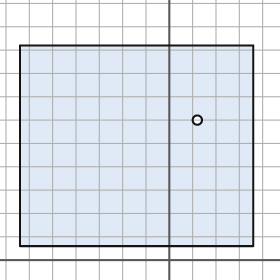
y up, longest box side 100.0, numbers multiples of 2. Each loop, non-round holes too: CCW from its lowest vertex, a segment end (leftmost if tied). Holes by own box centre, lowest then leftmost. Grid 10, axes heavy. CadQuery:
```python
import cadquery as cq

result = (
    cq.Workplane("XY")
    .moveTo(-64.0, 6.0)
    .lineTo(36.0, 6.0)
    .lineTo(36.0, 92.0)
    .lineTo(-64.0, 92.0)
    .close()
    .moveTo(12.0, 60.0)
    .circle(2.0)
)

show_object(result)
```